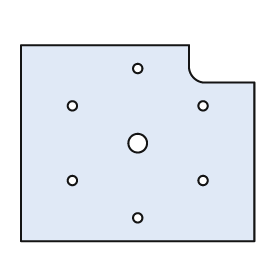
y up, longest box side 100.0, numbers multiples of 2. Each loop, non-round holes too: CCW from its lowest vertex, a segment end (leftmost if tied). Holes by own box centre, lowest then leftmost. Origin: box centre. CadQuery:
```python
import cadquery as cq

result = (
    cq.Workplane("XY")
    .moveTo(-50.0, -42.0)
    .lineTo(50.0, -42.0)
    .lineTo(50.0, 26.0)
    .lineTo(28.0, 26.0)
    .threePointArc((24.0, 28.0), (22.0, 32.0))
    .lineTo(22.0, 42.0)
    .lineTo(-50.0, 42.0)
    .close()
    .moveTo(0.0, -32.0)
    .circle(2.0)
    .moveTo(-28.0, -16.0)
    .circle(2.0)
    .moveTo(28.0, -16.0)
    .circle(2.0)
    .moveTo(0.0, 0.0)
    .circle(4.0)
    .moveTo(-28.0, 16.0)
    .circle(2.0)
    .moveTo(28.0, 16.0)
    .circle(2.0)
    .moveTo(0.0, 32.0)
    .circle(2.0)
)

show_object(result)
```